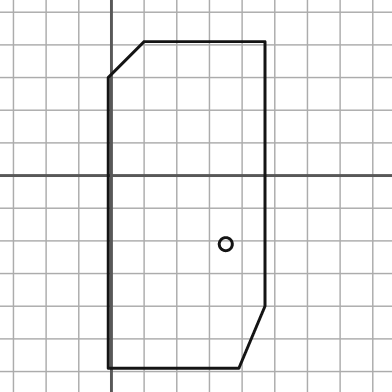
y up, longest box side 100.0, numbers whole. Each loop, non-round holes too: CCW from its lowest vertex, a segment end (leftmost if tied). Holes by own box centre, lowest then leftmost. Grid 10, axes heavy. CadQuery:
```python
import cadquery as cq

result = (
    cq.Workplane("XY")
    .moveTo(-1.0, -59.0)
    .lineTo(39.0, -59.0)
    .lineTo(47.0, -40.0)
    .lineTo(47.0, 41.0)
    .lineTo(10.0, 41.0)
    .lineTo(-1.0, 30.0)
    .close()
    .moveTo(35.0, -21.0)
    .circle(2.0)
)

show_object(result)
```